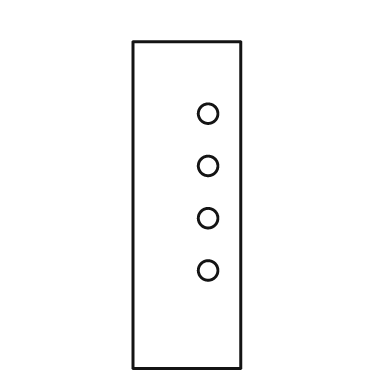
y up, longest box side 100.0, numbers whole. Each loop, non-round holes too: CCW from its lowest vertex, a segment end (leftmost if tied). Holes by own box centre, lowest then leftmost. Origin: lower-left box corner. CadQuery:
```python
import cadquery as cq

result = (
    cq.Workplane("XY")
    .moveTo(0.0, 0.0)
    .lineTo(33.0, 0.0)
    .lineTo(33.0, 100.0)
    .lineTo(0.0, 100.0)
    .close()
    .moveTo(23.0, 30.0)
    .circle(3.0)
    .moveTo(23.0, 46.0)
    .circle(3.0)
    .moveTo(23.0, 62.0)
    .circle(3.0)
    .moveTo(23.0, 78.0)
    .circle(3.0)
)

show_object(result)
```